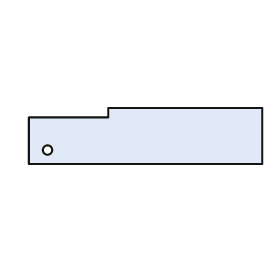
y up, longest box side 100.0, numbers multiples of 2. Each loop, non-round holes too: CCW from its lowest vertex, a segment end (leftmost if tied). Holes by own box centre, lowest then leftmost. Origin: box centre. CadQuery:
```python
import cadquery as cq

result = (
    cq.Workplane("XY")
    .moveTo(-50.0, -12.0)
    .lineTo(50.0, -12.0)
    .lineTo(50.0, 12.0)
    .lineTo(-16.0, 12.0)
    .lineTo(-16.0, 8.0)
    .lineTo(-50.0, 8.0)
    .close()
    .moveTo(-42.0, -6.0)
    .circle(2.0)
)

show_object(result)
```